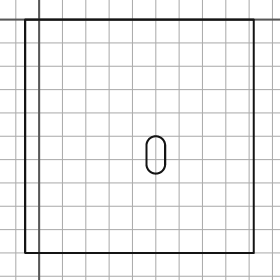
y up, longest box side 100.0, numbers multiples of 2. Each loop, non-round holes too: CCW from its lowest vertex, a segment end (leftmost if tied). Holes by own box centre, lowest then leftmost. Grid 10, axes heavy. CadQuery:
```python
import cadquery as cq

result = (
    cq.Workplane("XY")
    .moveTo(-6.0, -100.0)
    .lineTo(92.0, -100.0)
    .lineTo(92.0, 0.0)
    .lineTo(-6.0, 0.0)
    .close()
    .moveTo(46.0, -62.0)
    .threePointArc((50.0, -66.0), (54.0, -62.0))
    .lineTo(54.0, -54.0)
    .threePointArc((50.0, -50.0), (46.0, -54.0))
    .close()
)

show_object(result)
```